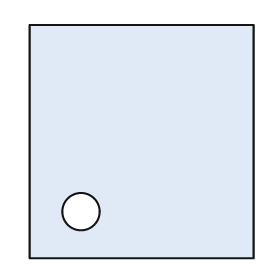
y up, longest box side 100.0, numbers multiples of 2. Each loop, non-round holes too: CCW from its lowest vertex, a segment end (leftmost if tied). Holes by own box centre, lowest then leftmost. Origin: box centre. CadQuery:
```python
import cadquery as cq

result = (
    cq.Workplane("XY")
    .moveTo(-48.0, -50.0)
    .lineTo(48.0, -50.0)
    .lineTo(48.0, 50.0)
    .lineTo(-48.0, 50.0)
    .close()
    .moveTo(-26.0, -30.0)
    .circle(8.0)
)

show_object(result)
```